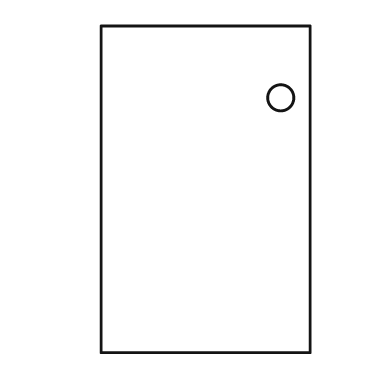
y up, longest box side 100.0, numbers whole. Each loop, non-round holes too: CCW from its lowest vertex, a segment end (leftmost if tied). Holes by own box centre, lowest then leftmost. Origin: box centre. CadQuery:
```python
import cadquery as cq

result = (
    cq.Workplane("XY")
    .moveTo(-32.0, -50.0)
    .lineTo(32.0, -50.0)
    .lineTo(32.0, 50.0)
    .lineTo(-32.0, 50.0)
    .close()
    .moveTo(23.0, 28.0)
    .circle(4.0)
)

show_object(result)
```